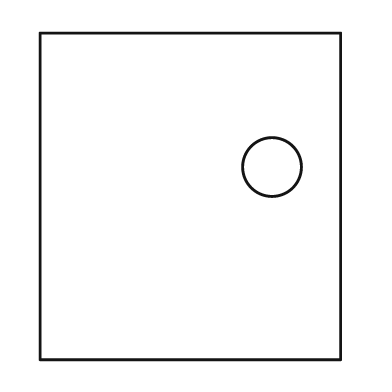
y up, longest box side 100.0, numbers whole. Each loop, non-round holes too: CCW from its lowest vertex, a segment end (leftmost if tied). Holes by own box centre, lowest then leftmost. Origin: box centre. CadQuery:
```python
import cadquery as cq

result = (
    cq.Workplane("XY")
    .moveTo(-46.0, -50.0)
    .lineTo(46.0, -50.0)
    .lineTo(46.0, 50.0)
    .lineTo(-46.0, 50.0)
    .close()
    .moveTo(25.0, 9.0)
    .circle(9.0)
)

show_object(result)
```